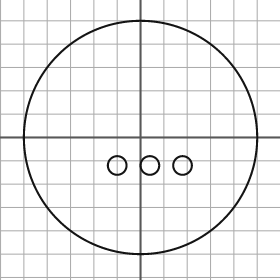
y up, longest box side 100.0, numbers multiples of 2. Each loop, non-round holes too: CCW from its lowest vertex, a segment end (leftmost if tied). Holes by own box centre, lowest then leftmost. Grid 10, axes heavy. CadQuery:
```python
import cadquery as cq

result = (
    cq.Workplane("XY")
    .moveTo(0.0, 0.0)
    .circle(50.0)
    .moveTo(-10.0, -12.0)
    .circle(4.0)
    .moveTo(4.0, -12.0)
    .circle(4.0)
    .moveTo(18.0, -12.0)
    .circle(4.0)
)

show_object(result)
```